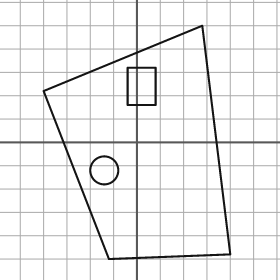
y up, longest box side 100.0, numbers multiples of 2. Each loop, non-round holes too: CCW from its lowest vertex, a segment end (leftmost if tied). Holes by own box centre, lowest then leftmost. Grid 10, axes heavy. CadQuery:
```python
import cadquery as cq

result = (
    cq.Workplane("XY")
    .moveTo(-12.0, -50.0)
    .lineTo(40.0, -48.0)
    .lineTo(28.0, 50.0)
    .lineTo(-40.0, 22.0)
    .close()
    .moveTo(-14.0, -12.0)
    .circle(6.0)
    .moveTo(-4.0, 16.0)
    .lineTo(8.0, 16.0)
    .lineTo(8.0, 32.0)
    .lineTo(-4.0, 32.0)
    .close()
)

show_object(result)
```